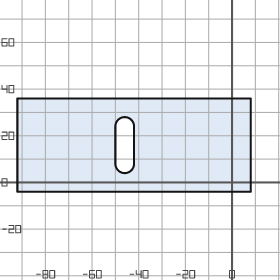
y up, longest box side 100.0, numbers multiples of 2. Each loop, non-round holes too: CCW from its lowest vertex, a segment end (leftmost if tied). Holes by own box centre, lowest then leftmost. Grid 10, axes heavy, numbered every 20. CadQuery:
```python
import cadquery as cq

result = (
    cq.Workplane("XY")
    .moveTo(-92.0, -4.0)
    .lineTo(8.0, -4.0)
    .lineTo(8.0, 36.0)
    .lineTo(-92.0, 36.0)
    .close()
    .moveTo(-50.0, 8.0)
    .threePointArc((-46.0, 4.0), (-42.0, 8.0))
    .lineTo(-42.0, 24.0)
    .threePointArc((-46.0, 28.0), (-50.0, 24.0))
    .close()
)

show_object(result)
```